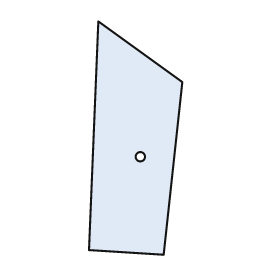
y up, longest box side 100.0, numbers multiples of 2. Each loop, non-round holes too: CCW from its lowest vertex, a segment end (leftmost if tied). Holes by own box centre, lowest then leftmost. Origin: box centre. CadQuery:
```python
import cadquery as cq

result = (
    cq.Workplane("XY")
    .moveTo(12.0, -50.0)
    .lineTo(20.0, 24.0)
    .lineTo(-16.0, 50.0)
    .lineTo(-20.0, -48.0)
    .close()
    .moveTo(2.0, -8.0)
    .circle(2.0)
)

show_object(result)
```